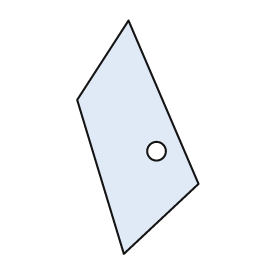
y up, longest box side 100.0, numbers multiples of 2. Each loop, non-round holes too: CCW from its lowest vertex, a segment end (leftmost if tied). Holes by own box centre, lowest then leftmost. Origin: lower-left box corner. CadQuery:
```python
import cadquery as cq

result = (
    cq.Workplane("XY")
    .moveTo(20.0, 0.0)
    .lineTo(52.0, 30.0)
    .lineTo(22.0, 100.0)
    .lineTo(0.0, 66.0)
    .close()
    .moveTo(34.0, 44.0)
    .circle(4.0)
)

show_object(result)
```